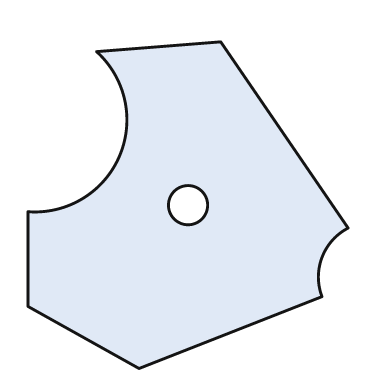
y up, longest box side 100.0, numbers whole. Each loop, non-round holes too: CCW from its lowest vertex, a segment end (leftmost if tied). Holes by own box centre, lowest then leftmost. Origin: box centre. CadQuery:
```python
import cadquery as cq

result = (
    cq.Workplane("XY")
    .moveTo(-15.0, -50.0)
    .lineTo(41.0, -28.0)
    .threePointArc((41.0, -16.0), (49.0, -7.0))
    .lineTo(10.0, 50.0)
    .lineTo(-28.0, 47.0)
    .threePointArc((-21.0, 15.0), (-49.0, -2.0))
    .lineTo(-49.0, -31.0)
    .close()
    .moveTo(0.0, 0.0)
    .circle(6.0)
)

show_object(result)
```